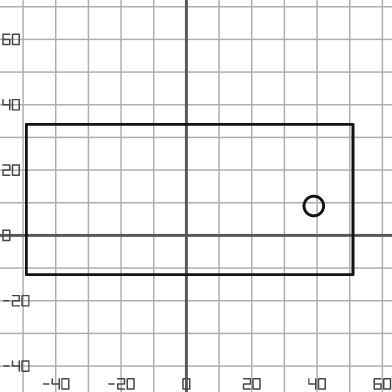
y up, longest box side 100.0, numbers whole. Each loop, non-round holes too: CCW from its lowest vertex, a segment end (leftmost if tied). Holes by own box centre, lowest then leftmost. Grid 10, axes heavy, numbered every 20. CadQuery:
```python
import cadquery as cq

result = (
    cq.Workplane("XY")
    .moveTo(-49.0, -12.0)
    .lineTo(51.0, -12.0)
    .lineTo(51.0, 34.0)
    .lineTo(-49.0, 34.0)
    .close()
    .moveTo(39.0, 9.0)
    .circle(3.0)
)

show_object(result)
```